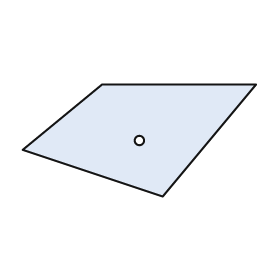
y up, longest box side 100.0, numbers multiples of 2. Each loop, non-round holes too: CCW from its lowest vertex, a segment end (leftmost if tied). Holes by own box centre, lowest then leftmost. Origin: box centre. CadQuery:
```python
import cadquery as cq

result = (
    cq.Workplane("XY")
    .moveTo(10.0, -24.0)
    .lineTo(50.0, 24.0)
    .lineTo(-16.0, 24.0)
    .lineTo(-50.0, -4.0)
    .close()
    .moveTo(0.0, 0.0)
    .circle(2.0)
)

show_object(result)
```